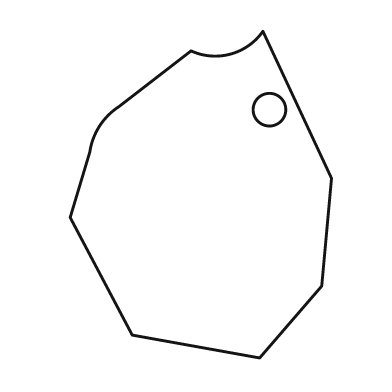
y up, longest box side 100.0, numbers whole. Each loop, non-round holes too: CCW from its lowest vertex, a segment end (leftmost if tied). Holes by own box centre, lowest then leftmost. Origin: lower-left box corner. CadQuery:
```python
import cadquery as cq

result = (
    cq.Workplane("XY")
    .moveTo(58.0, 0.0)
    .lineTo(77.0, 22.0)
    .lineTo(80.0, 55.0)
    .lineTo(59.0, 100.0)
    .threePointArc((49.0, 93.0), (37.0, 94.0))
    .lineTo(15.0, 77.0)
    .threePointArc((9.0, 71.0), (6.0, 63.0))
    .lineTo(0.0, 43.0)
    .lineTo(19.0, 7.0)
    .close()
    .moveTo(61.0, 76.0)
    .circle(5.0)
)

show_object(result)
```